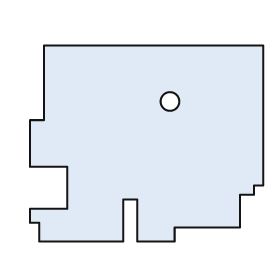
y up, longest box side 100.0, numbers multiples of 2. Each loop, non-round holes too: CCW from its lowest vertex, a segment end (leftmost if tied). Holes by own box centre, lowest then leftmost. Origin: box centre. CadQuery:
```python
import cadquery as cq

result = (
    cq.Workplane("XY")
    .moveTo(-46.0, -42.0)
    .lineTo(-10.0, -42.0)
    .lineTo(-10.0, -24.0)
    .lineTo(-4.0, -24.0)
    .lineTo(-4.0, -42.0)
    .lineTo(12.0, -42.0)
    .lineTo(12.0, -36.0)
    .lineTo(40.0, -36.0)
    .lineTo(40.0, -22.0)
    .lineTo(46.0, -22.0)
    .lineTo(46.0, -18.0)
    .lineTo(50.0, -18.0)
    .lineTo(50.0, 42.0)
    .lineTo(-44.0, 42.0)
    .lineTo(-44.0, 10.0)
    .lineTo(-50.0, 10.0)
    .lineTo(-50.0, -10.0)
    .lineTo(-34.0, -10.0)
    .lineTo(-34.0, -28.0)
    .lineTo(-50.0, -28.0)
    .lineTo(-50.0, -34.0)
    .lineTo(-46.0, -34.0)
    .close()
    .moveTo(10.0, 18.0)
    .circle(4.0)
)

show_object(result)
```